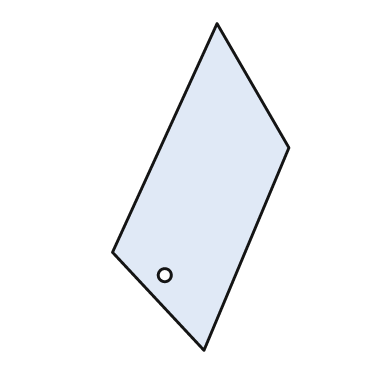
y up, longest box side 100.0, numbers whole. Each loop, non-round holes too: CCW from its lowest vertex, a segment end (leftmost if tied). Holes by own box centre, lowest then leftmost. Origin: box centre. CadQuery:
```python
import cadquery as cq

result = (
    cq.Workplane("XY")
    .moveTo(1.0, -50.0)
    .lineTo(27.0, 12.0)
    .lineTo(5.0, 50.0)
    .lineTo(-27.0, -20.0)
    .close()
    .moveTo(-11.0, -27.0)
    .circle(2.0)
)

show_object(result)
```